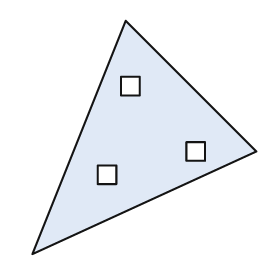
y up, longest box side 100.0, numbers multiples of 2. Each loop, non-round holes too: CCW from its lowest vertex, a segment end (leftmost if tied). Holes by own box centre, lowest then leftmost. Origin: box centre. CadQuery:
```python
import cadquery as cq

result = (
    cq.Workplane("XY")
    .moveTo(-48.0, -50.0)
    .lineTo(48.0, -6.0)
    .lineTo(-8.0, 50.0)
    .close()
    .moveTo(-20.0, -20.0)
    .lineTo(-12.0, -20.0)
    .lineTo(-12.0, -12.0)
    .lineTo(-20.0, -12.0)
    .close()
    .moveTo(18.0, -10.0)
    .lineTo(26.0, -10.0)
    .lineTo(26.0, -2.0)
    .lineTo(18.0, -2.0)
    .close()
    .moveTo(-10.0, 18.0)
    .lineTo(-2.0, 18.0)
    .lineTo(-2.0, 26.0)
    .lineTo(-10.0, 26.0)
    .close()
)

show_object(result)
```